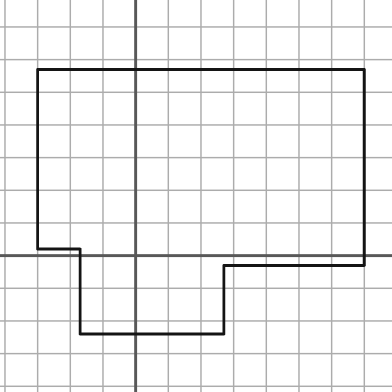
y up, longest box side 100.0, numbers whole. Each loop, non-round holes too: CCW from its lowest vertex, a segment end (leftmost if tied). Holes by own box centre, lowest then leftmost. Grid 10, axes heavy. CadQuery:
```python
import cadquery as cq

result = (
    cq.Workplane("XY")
    .moveTo(-17.0, -24.0)
    .lineTo(27.0, -24.0)
    .lineTo(27.0, -3.0)
    .lineTo(70.0, -3.0)
    .lineTo(70.0, 57.0)
    .lineTo(-30.0, 57.0)
    .lineTo(-30.0, 2.0)
    .lineTo(-17.0, 2.0)
    .close()
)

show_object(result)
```